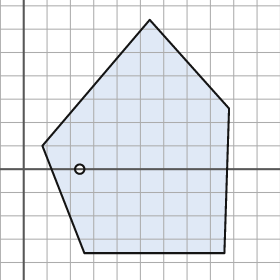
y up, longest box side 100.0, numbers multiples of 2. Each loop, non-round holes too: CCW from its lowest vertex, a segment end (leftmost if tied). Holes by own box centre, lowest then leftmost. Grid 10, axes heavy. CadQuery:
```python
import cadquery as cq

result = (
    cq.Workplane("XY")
    .moveTo(26.0, -36.0)
    .lineTo(86.0, -36.0)
    .lineTo(88.0, 26.0)
    .lineTo(54.0, 64.0)
    .lineTo(8.0, 10.0)
    .close()
    .moveTo(24.0, 0.0)
    .circle(2.0)
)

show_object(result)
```